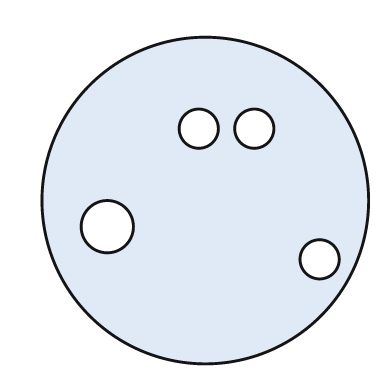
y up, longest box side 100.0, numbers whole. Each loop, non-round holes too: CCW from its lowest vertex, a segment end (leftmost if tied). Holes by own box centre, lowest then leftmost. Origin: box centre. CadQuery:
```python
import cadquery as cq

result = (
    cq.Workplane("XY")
    .moveTo(0.0, 0.0)
    .circle(50.0)
    .moveTo(35.0, -18.0)
    .circle(6.0)
    .moveTo(-30.0, -8.0)
    .circle(8.0)
    .moveTo(-2.0, 22.0)
    .circle(6.0)
    .moveTo(15.0, 22.0)
    .circle(6.0)
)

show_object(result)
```